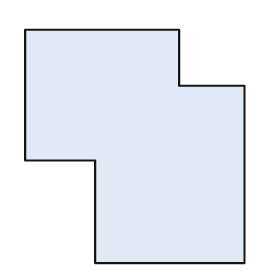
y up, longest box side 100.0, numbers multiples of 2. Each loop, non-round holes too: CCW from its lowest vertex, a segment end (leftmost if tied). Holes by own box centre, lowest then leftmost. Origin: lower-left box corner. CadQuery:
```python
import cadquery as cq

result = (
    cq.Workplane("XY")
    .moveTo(30.0, 0.0)
    .lineTo(94.0, 0.0)
    .lineTo(94.0, 76.0)
    .lineTo(66.0, 76.0)
    .lineTo(66.0, 100.0)
    .lineTo(0.0, 100.0)
    .lineTo(0.0, 44.0)
    .lineTo(30.0, 44.0)
    .close()
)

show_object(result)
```